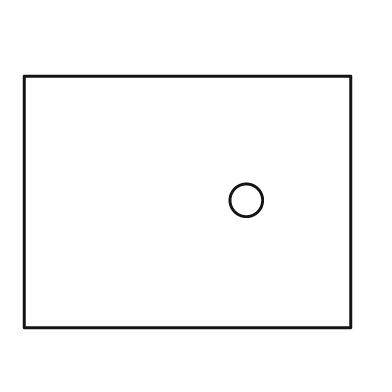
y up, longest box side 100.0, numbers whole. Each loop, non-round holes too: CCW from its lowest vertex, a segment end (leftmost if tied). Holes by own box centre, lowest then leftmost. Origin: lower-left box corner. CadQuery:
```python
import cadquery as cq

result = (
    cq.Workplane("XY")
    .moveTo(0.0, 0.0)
    .lineTo(100.0, 0.0)
    .lineTo(100.0, 77.0)
    .lineTo(0.0, 77.0)
    .close()
    .moveTo(68.0, 39.0)
    .circle(5.0)
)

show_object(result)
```